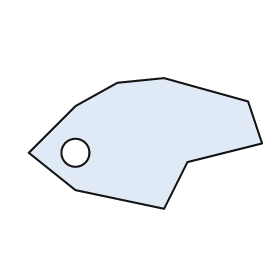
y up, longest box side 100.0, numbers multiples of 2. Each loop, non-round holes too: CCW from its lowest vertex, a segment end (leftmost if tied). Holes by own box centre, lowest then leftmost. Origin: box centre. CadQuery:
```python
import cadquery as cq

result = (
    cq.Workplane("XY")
    .moveTo(8.0, -28.0)
    .lineTo(18.0, -8.0)
    .lineTo(50.0, 0.0)
    .lineTo(44.0, 18.0)
    .lineTo(8.0, 28.0)
    .lineTo(-12.0, 26.0)
    .lineTo(-30.0, 16.0)
    .lineTo(-50.0, -4.0)
    .lineTo(-30.0, -20.0)
    .close()
    .moveTo(-30.0, -4.0)
    .circle(6.0)
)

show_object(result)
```